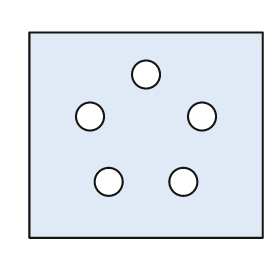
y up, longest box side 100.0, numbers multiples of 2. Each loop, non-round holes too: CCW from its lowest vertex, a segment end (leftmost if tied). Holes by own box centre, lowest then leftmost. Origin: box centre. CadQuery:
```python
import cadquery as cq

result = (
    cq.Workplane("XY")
    .moveTo(-50.0, -44.0)
    .lineTo(50.0, -44.0)
    .lineTo(50.0, 44.0)
    .lineTo(-50.0, 44.0)
    .close()
    .moveTo(-16.0, -20.0)
    .circle(6.0)
    .moveTo(16.0, -20.0)
    .circle(6.0)
    .moveTo(-24.0, 8.0)
    .circle(6.0)
    .moveTo(24.0, 8.0)
    .circle(6.0)
    .moveTo(0.0, 26.0)
    .circle(6.0)
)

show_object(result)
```